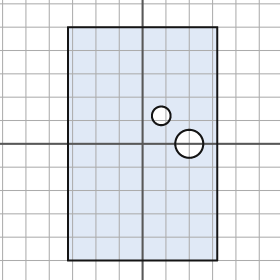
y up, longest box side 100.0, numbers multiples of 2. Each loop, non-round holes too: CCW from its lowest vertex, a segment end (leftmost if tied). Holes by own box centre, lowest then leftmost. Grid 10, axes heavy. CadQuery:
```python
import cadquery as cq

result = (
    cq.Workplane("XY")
    .moveTo(-32.0, -50.0)
    .lineTo(32.0, -50.0)
    .lineTo(32.0, 50.0)
    .lineTo(-32.0, 50.0)
    .close()
    .moveTo(20.0, 0.0)
    .circle(6.0)
    .moveTo(8.0, 12.0)
    .circle(4.0)
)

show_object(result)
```